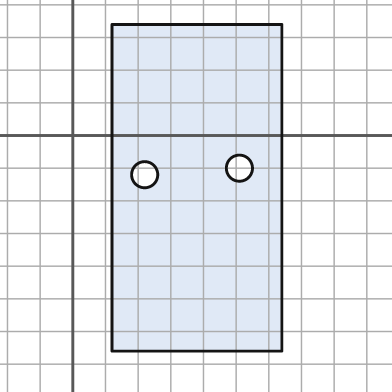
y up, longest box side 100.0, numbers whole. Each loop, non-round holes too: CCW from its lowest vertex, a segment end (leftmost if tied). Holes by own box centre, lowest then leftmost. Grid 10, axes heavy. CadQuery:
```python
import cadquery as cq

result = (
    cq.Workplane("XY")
    .moveTo(12.0, -66.0)
    .lineTo(64.0, -66.0)
    .lineTo(64.0, 34.0)
    .lineTo(12.0, 34.0)
    .close()
    .moveTo(22.0, -12.0)
    .circle(4.0)
    .moveTo(51.0, -10.0)
    .circle(4.0)
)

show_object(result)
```